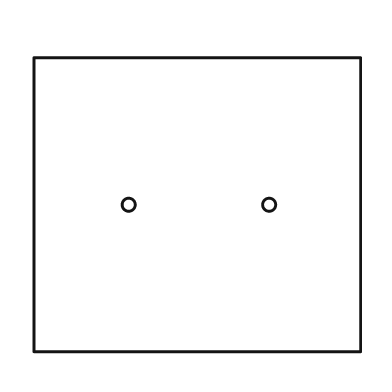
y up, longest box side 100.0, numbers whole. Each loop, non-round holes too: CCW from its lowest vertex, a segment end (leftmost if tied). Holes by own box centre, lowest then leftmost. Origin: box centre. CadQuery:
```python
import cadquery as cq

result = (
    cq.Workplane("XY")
    .moveTo(-50.0, -45.0)
    .lineTo(50.0, -45.0)
    .lineTo(50.0, 45.0)
    .lineTo(-50.0, 45.0)
    .close()
    .moveTo(-21.0, 0.0)
    .circle(2.0)
    .moveTo(22.0, 0.0)
    .circle(2.0)
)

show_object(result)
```